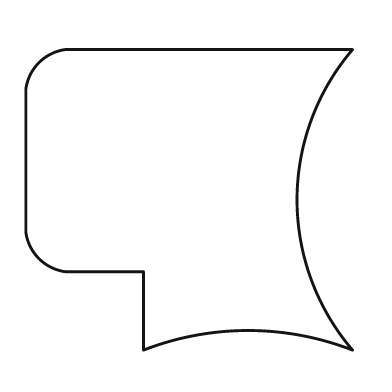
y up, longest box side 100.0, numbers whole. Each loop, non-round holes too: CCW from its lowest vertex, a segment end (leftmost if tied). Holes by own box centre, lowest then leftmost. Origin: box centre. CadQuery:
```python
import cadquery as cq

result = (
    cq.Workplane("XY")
    .moveTo(-14.0, -46.0)
    .threePointArc((18.0, -40.0), (50.0, -46.0))
    .threePointArc((33.0, 0.0), (50.0, 46.0))
    .lineTo(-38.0, 46.0)
    .threePointArc((-46.0, 42.0), (-50.0, 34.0))
    .lineTo(-50.0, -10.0)
    .threePointArc((-46.0, -18.0), (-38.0, -22.0))
    .lineTo(-14.0, -22.0)
    .close()
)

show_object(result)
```